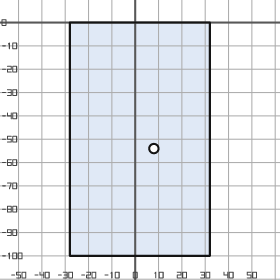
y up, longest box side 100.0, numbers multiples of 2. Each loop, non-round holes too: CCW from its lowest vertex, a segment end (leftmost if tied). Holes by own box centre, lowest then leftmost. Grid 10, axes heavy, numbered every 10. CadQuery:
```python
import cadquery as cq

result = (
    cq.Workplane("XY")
    .moveTo(-28.0, -100.0)
    .lineTo(32.0, -100.0)
    .lineTo(32.0, 0.0)
    .lineTo(-28.0, 0.0)
    .close()
    .moveTo(8.0, -54.0)
    .circle(2.0)
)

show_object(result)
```